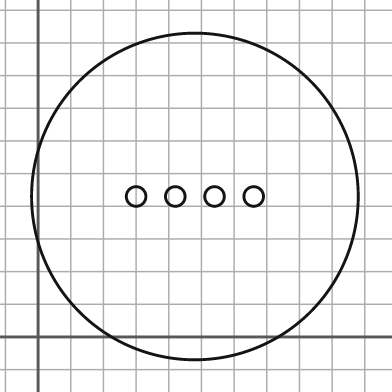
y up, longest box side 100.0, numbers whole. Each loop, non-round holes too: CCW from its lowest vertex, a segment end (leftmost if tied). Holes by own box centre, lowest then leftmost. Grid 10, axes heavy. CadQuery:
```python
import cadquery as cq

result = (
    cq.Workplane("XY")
    .moveTo(48.0, 43.0)
    .circle(50.0)
    .moveTo(30.0, 43.0)
    .circle(3.0)
    .moveTo(42.0, 43.0)
    .circle(3.0)
    .moveTo(54.0, 43.0)
    .circle(3.0)
    .moveTo(66.0, 43.0)
    .circle(3.0)
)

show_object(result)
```